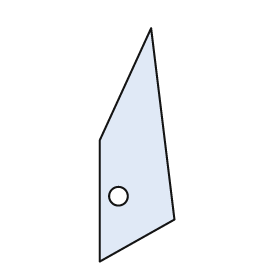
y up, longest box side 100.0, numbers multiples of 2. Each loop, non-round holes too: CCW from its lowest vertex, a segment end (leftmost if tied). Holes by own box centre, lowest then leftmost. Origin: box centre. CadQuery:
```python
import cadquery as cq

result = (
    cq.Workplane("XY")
    .moveTo(-16.0, -50.0)
    .lineTo(16.0, -32.0)
    .lineTo(6.0, 50.0)
    .lineTo(-16.0, 2.0)
    .close()
    .moveTo(-8.0, -22.0)
    .circle(4.0)
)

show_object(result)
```